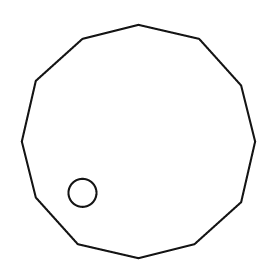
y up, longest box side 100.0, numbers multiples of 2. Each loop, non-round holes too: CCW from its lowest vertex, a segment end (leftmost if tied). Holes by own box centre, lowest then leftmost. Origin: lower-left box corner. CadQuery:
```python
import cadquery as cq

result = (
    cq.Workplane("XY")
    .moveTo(50.0, 0.0)
    .lineTo(74.0, 6.0)
    .lineTo(94.0, 24.0)
    .lineTo(100.0, 50.0)
    .lineTo(94.0, 74.0)
    .lineTo(76.0, 94.0)
    .lineTo(50.0, 100.0)
    .lineTo(26.0, 94.0)
    .lineTo(6.0, 76.0)
    .lineTo(0.0, 50.0)
    .lineTo(6.0, 26.0)
    .lineTo(24.0, 6.0)
    .close()
    .moveTo(26.0, 28.0)
    .circle(6.0)
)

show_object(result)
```